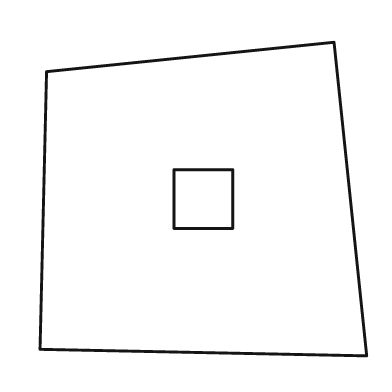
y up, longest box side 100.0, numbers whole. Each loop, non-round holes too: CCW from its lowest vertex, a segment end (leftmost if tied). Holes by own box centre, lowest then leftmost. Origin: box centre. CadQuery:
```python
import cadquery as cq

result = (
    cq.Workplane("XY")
    .moveTo(50.0, -48.0)
    .lineTo(40.0, 48.0)
    .lineTo(-48.0, 39.0)
    .lineTo(-50.0, -46.0)
    .close()
    .moveTo(-9.0, -9.0)
    .lineTo(9.0, -9.0)
    .lineTo(9.0, 9.0)
    .lineTo(-9.0, 9.0)
    .close()
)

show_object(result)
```